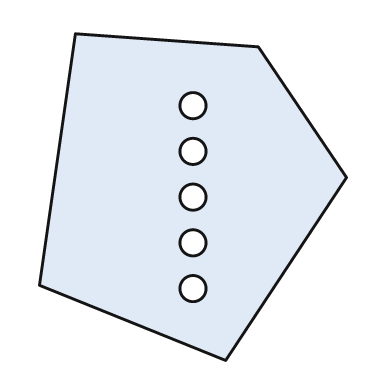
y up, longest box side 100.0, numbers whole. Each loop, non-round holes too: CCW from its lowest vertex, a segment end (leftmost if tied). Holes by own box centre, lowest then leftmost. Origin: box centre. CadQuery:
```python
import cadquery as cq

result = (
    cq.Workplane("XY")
    .moveTo(10.0, -50.0)
    .lineTo(47.0, 6.0)
    .lineTo(20.0, 46.0)
    .lineTo(-36.0, 50.0)
    .lineTo(-47.0, -27.0)
    .close()
    .moveTo(0.0, -28.0)
    .circle(4.0)
    .moveTo(0.0, -14.0)
    .circle(4.0)
    .moveTo(0.0, 0.0)
    .circle(4.0)
    .moveTo(0.0, 14.0)
    .circle(4.0)
    .moveTo(0.0, 28.0)
    .circle(4.0)
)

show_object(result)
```